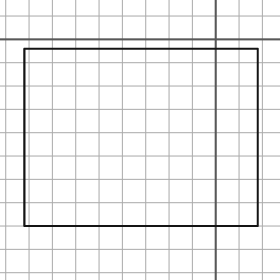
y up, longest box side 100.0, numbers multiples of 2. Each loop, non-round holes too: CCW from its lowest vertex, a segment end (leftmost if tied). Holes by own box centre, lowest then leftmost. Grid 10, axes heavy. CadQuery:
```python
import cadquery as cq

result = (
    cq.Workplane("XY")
    .moveTo(-82.0, -80.0)
    .lineTo(18.0, -80.0)
    .lineTo(18.0, -4.0)
    .lineTo(-82.0, -4.0)
    .close()
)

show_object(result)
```